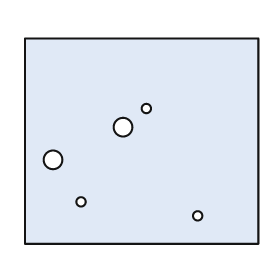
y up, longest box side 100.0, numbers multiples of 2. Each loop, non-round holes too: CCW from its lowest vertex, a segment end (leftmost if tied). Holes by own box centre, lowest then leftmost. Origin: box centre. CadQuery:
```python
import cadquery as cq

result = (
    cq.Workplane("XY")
    .moveTo(-50.0, -44.0)
    .lineTo(50.0, -44.0)
    .lineTo(50.0, 44.0)
    .lineTo(-50.0, 44.0)
    .close()
    .moveTo(24.0, -32.0)
    .circle(2.0)
    .moveTo(-26.0, -26.0)
    .circle(2.0)
    .moveTo(-38.0, -8.0)
    .circle(4.0)
    .moveTo(-8.0, 6.0)
    .circle(4.0)
    .moveTo(2.0, 14.0)
    .circle(2.0)
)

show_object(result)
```